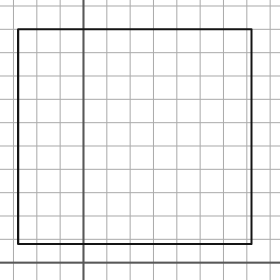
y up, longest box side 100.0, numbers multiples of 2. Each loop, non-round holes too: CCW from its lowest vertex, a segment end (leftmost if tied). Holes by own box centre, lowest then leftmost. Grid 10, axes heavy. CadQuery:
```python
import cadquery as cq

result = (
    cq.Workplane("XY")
    .moveTo(-28.0, 8.0)
    .lineTo(72.0, 8.0)
    .lineTo(72.0, 100.0)
    .lineTo(-28.0, 100.0)
    .close()
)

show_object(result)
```